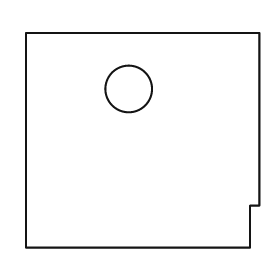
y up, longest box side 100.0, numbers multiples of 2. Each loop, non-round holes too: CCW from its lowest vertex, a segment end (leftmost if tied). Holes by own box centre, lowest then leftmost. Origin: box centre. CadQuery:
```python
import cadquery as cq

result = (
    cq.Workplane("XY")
    .moveTo(-50.0, -46.0)
    .lineTo(46.0, -46.0)
    .lineTo(46.0, -28.0)
    .lineTo(50.0, -28.0)
    .lineTo(50.0, 46.0)
    .lineTo(-50.0, 46.0)
    .close()
    .moveTo(-6.0, 22.0)
    .circle(10.0)
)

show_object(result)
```